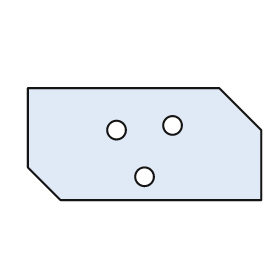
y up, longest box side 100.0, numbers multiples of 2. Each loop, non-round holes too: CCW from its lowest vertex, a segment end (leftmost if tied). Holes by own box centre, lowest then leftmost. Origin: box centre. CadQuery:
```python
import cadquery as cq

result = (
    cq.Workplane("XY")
    .moveTo(-36.0, -24.0)
    .lineTo(50.0, -24.0)
    .lineTo(50.0, 6.0)
    .lineTo(32.0, 24.0)
    .lineTo(-50.0, 24.0)
    .lineTo(-50.0, -10.0)
    .close()
    .moveTo(0.0, -14.0)
    .circle(4.0)
    .moveTo(-12.0, 6.0)
    .circle(4.0)
    .moveTo(12.0, 8.0)
    .circle(4.0)
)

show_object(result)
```